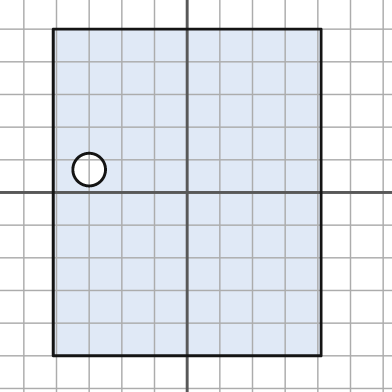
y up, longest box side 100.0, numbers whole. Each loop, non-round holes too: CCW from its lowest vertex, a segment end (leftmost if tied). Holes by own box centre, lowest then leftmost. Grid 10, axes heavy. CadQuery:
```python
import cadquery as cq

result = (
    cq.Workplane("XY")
    .moveTo(-41.0, -50.0)
    .lineTo(41.0, -50.0)
    .lineTo(41.0, 50.0)
    .lineTo(-41.0, 50.0)
    .close()
    .moveTo(-30.0, 7.0)
    .circle(5.0)
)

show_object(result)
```